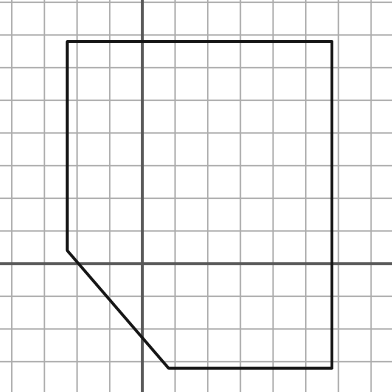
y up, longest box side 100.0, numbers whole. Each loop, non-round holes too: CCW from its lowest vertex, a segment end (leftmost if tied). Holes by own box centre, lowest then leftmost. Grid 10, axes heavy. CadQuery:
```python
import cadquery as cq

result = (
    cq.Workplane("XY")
    .moveTo(8.0, -32.0)
    .lineTo(58.0, -32.0)
    .lineTo(58.0, 68.0)
    .lineTo(-23.0, 68.0)
    .lineTo(-23.0, 4.0)
    .close()
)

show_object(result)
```